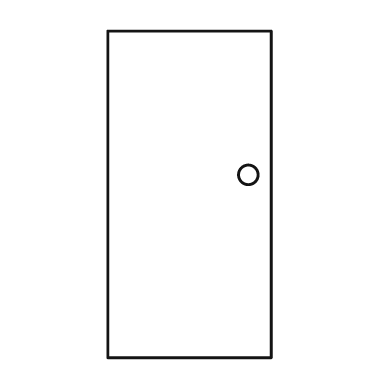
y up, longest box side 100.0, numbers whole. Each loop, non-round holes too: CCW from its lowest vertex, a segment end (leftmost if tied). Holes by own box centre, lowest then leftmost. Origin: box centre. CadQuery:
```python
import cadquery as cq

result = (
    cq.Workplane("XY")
    .moveTo(-25.0, -50.0)
    .lineTo(25.0, -50.0)
    .lineTo(25.0, 50.0)
    .lineTo(-25.0, 50.0)
    .close()
    .moveTo(18.0, 6.0)
    .circle(3.0)
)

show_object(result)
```